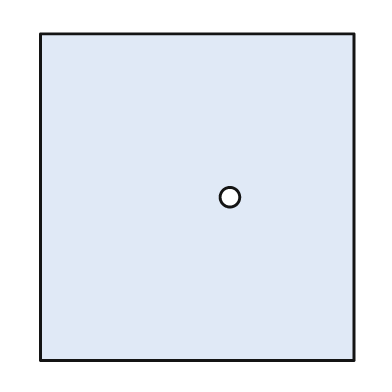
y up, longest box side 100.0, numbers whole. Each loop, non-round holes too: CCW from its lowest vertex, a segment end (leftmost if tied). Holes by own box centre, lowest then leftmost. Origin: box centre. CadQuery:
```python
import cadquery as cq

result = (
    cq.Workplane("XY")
    .moveTo(-48.0, -50.0)
    .lineTo(48.0, -50.0)
    .lineTo(48.0, 50.0)
    .lineTo(-48.0, 50.0)
    .close()
    .moveTo(10.0, 0.0)
    .circle(3.0)
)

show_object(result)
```